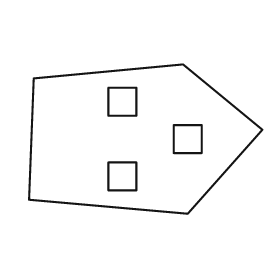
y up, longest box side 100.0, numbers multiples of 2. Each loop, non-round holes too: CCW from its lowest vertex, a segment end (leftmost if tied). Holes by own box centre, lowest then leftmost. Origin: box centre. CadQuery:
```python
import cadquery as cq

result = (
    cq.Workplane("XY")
    .moveTo(18.0, -32.0)
    .lineTo(50.0, 4.0)
    .lineTo(16.0, 32.0)
    .lineTo(-48.0, 26.0)
    .lineTo(-50.0, -26.0)
    .close()
    .moveTo(-16.0, -22.0)
    .lineTo(-4.0, -22.0)
    .lineTo(-4.0, -10.0)
    .lineTo(-16.0, -10.0)
    .close()
    .moveTo(12.0, -6.0)
    .lineTo(24.0, -6.0)
    .lineTo(24.0, 6.0)
    .lineTo(12.0, 6.0)
    .close()
    .moveTo(-16.0, 10.0)
    .lineTo(-4.0, 10.0)
    .lineTo(-4.0, 22.0)
    .lineTo(-16.0, 22.0)
    .close()
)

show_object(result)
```